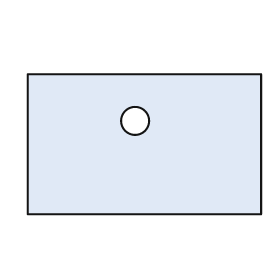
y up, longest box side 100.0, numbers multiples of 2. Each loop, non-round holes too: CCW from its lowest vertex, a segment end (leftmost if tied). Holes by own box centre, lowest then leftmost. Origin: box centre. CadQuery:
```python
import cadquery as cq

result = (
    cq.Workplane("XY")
    .moveTo(-50.0, -30.0)
    .lineTo(50.0, -30.0)
    .lineTo(50.0, 30.0)
    .lineTo(-50.0, 30.0)
    .close()
    .moveTo(-4.0, 10.0)
    .circle(6.0)
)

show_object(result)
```